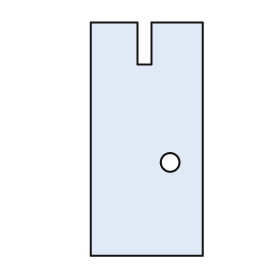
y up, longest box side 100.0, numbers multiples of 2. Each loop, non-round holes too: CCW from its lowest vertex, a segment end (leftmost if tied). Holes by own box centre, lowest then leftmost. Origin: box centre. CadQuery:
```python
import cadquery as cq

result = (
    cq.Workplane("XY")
    .moveTo(-24.0, -50.0)
    .lineTo(24.0, -50.0)
    .lineTo(24.0, 50.0)
    .lineTo(2.0, 50.0)
    .lineTo(2.0, 32.0)
    .lineTo(-4.0, 32.0)
    .lineTo(-4.0, 50.0)
    .lineTo(-24.0, 50.0)
    .close()
    .moveTo(10.0, -10.0)
    .circle(4.0)
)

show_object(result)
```